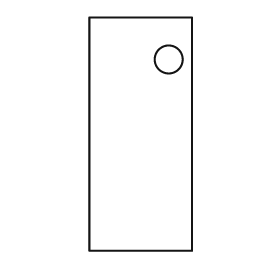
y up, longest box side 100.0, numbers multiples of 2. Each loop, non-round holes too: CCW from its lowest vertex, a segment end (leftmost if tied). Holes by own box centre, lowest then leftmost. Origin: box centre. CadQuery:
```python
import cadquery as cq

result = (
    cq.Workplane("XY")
    .moveTo(-22.0, -50.0)
    .lineTo(22.0, -50.0)
    .lineTo(22.0, 50.0)
    .lineTo(-22.0, 50.0)
    .close()
    .moveTo(12.0, 32.0)
    .circle(6.0)
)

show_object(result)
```